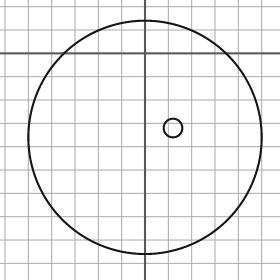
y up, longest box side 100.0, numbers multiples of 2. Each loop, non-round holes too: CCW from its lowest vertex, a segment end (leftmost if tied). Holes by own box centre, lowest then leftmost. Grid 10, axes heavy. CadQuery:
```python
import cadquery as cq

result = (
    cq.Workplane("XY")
    .moveTo(0.0, -36.0)
    .circle(50.0)
    .moveTo(12.0, -32.0)
    .circle(4.0)
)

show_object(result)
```